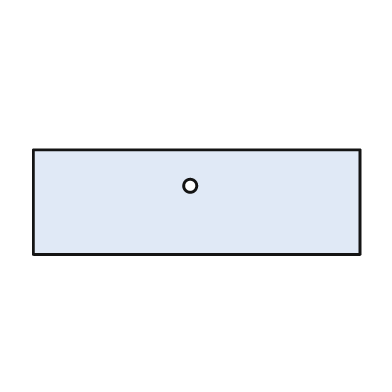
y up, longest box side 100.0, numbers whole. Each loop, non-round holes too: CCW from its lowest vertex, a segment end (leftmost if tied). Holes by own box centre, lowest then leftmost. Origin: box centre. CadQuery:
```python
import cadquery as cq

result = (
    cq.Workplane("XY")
    .moveTo(-50.0, -16.0)
    .lineTo(50.0, -16.0)
    .lineTo(50.0, 16.0)
    .lineTo(-50.0, 16.0)
    .close()
    .moveTo(-2.0, 5.0)
    .circle(2.0)
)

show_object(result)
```